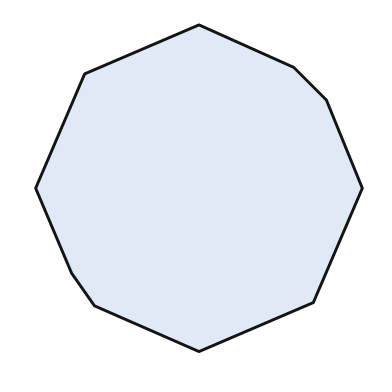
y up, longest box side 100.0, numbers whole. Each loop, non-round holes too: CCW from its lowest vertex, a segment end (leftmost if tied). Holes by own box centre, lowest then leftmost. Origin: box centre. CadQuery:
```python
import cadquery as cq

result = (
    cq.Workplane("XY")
    .moveTo(0.0, -50.0)
    .lineTo(35.0, -35.0)
    .lineTo(50.0, 0.0)
    .lineTo(39.0, 27.0)
    .lineTo(29.0, 37.0)
    .lineTo(0.0, 50.0)
    .lineTo(-35.0, 35.0)
    .lineTo(-50.0, 0.0)
    .lineTo(-39.0, -26.0)
    .lineTo(-32.0, -36.0)
    .close()
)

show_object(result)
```